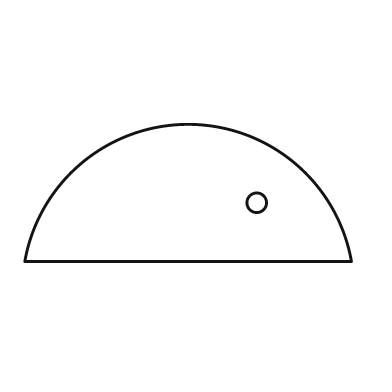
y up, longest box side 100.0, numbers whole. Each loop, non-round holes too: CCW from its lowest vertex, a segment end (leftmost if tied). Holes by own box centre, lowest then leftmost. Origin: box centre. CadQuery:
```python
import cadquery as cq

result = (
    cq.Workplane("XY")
    .moveTo(-50.0, -21.0)
    .lineTo(50.0, -21.0)
    .threePointArc((0.0, 21.0), (-50.0, -21.0))
    .close()
    .moveTo(21.0, -3.0)
    .circle(3.0)
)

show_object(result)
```